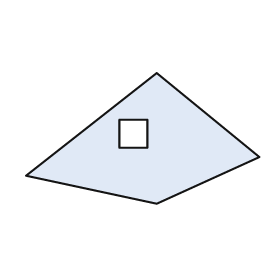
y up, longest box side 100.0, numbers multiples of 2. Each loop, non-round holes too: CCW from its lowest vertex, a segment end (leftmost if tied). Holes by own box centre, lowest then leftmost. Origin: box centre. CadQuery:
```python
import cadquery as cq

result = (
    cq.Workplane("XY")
    .moveTo(6.0, -28.0)
    .lineTo(50.0, -8.0)
    .lineTo(6.0, 28.0)
    .lineTo(-50.0, -16.0)
    .close()
    .moveTo(-10.0, -4.0)
    .lineTo(2.0, -4.0)
    .lineTo(2.0, 8.0)
    .lineTo(-10.0, 8.0)
    .close()
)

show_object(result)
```